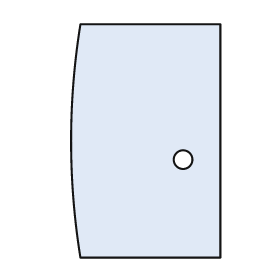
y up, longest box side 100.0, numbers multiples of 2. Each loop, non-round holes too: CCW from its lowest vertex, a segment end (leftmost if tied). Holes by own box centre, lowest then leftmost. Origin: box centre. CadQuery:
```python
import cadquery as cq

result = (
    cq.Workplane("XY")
    .moveTo(-28.0, -50.0)
    .lineTo(32.0, -50.0)
    .lineTo(32.0, 50.0)
    .lineTo(-28.0, 50.0)
    .threePointArc((-32.0, 0.0), (-28.0, -50.0))
    .close()
    .moveTo(16.0, -8.0)
    .circle(4.0)
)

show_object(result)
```